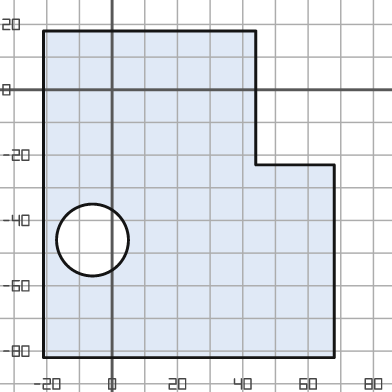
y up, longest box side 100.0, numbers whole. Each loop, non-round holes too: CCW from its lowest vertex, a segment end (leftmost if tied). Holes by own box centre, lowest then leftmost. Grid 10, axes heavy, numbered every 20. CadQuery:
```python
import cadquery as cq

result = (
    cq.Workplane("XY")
    .moveTo(-21.0, -82.0)
    .lineTo(68.0, -82.0)
    .lineTo(68.0, -23.0)
    .lineTo(44.0, -23.0)
    .lineTo(44.0, 18.0)
    .lineTo(-21.0, 18.0)
    .close()
    .moveTo(-6.0, -46.0)
    .circle(11.0)
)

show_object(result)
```